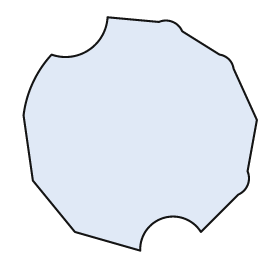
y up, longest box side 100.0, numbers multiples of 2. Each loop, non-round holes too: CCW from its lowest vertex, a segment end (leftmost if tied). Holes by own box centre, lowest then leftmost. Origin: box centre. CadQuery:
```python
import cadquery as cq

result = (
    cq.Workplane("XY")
    .moveTo(0.0, -50.0)
    .threePointArc((10.0, -36.0), (26.0, -42.0))
    .lineTo(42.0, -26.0)
    .threePointArc((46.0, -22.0), (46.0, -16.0))
    .lineTo(50.0, 6.0)
    .lineTo(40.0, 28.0)
    .threePointArc((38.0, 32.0), (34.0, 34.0))
    .lineTo(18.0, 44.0)
    .threePointArc((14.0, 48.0), (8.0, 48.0))
    .lineTo(-14.0, 50.0)
    .threePointArc((-22.0, 36.0), (-38.0, 34.0))
    .threePointArc((-46.0, 22.0), (-50.0, 8.0))
    .lineTo(-46.0, -20.0)
    .lineTo(-28.0, -42.0)
    .close()
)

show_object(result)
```